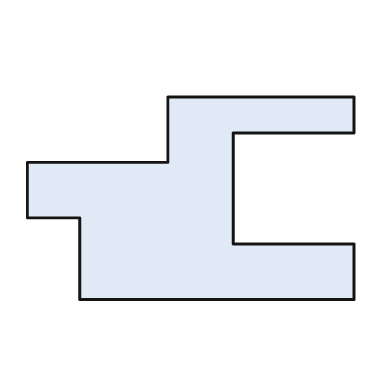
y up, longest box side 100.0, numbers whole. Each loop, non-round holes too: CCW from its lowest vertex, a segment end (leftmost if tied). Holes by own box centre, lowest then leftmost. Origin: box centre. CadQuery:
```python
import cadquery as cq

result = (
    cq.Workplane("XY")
    .moveTo(-34.0, -31.0)
    .lineTo(50.0, -31.0)
    .lineTo(50.0, -14.0)
    .lineTo(13.0, -14.0)
    .lineTo(13.0, 20.0)
    .lineTo(50.0, 20.0)
    .lineTo(50.0, 31.0)
    .lineTo(-7.0, 31.0)
    .lineTo(-7.0, 11.0)
    .lineTo(-50.0, 11.0)
    .lineTo(-50.0, -6.0)
    .lineTo(-34.0, -6.0)
    .close()
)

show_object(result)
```